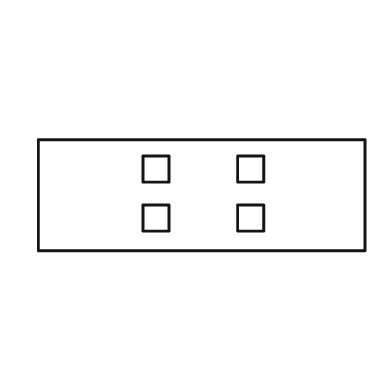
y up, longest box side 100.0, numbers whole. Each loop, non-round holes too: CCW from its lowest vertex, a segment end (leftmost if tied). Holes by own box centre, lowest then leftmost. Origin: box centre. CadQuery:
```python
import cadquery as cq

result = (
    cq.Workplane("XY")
    .moveTo(-50.0, -17.0)
    .lineTo(50.0, -17.0)
    .lineTo(50.0, 17.0)
    .lineTo(-50.0, 17.0)
    .close()
    .moveTo(-18.0, -11.0)
    .lineTo(-10.0, -11.0)
    .lineTo(-10.0, -3.0)
    .lineTo(-18.0, -3.0)
    .close()
    .moveTo(11.0, -11.0)
    .lineTo(19.0, -11.0)
    .lineTo(19.0, -3.0)
    .lineTo(11.0, -3.0)
    .close()
    .moveTo(-18.0, 4.0)
    .lineTo(-10.0, 4.0)
    .lineTo(-10.0, 12.0)
    .lineTo(-18.0, 12.0)
    .close()
    .moveTo(11.0, 4.0)
    .lineTo(19.0, 4.0)
    .lineTo(19.0, 12.0)
    .lineTo(11.0, 12.0)
    .close()
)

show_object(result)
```